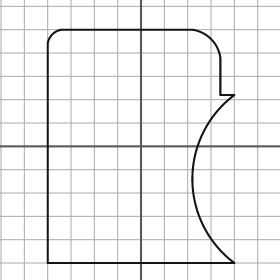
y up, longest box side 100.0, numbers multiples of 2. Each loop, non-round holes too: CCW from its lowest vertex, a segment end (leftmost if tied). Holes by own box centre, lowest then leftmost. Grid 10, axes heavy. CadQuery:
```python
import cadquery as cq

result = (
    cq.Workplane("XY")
    .moveTo(-40.0, -50.0)
    .lineTo(40.0, -50.0)
    .threePointArc((22.0, -14.0), (40.0, 22.0))
    .lineTo(34.0, 22.0)
    .lineTo(34.0, 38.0)
    .threePointArc((30.0, 46.0), (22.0, 50.0))
    .lineTo(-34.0, 50.0)
    .threePointArc((-38.0, 48.0), (-40.0, 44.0))
    .close()
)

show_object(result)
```